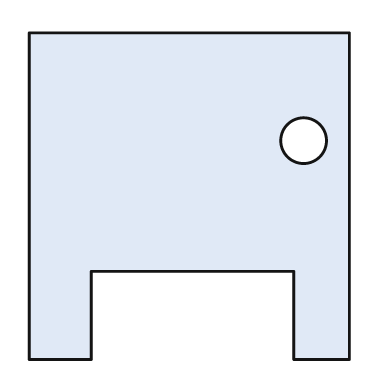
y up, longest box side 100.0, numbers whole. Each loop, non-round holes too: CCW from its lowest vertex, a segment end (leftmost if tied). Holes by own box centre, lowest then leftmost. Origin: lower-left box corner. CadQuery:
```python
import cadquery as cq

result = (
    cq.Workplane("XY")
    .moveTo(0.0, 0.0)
    .lineTo(19.0, 0.0)
    .lineTo(19.0, 27.0)
    .lineTo(81.0, 27.0)
    .lineTo(81.0, 0.0)
    .lineTo(98.0, 0.0)
    .lineTo(98.0, 100.0)
    .lineTo(0.0, 100.0)
    .close()
    .moveTo(84.0, 67.0)
    .circle(7.0)
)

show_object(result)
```